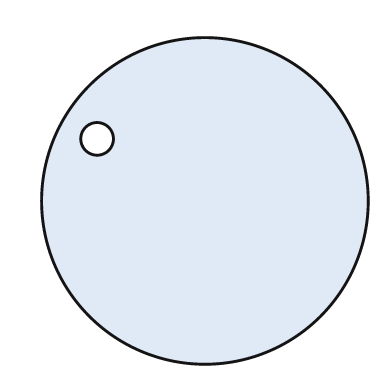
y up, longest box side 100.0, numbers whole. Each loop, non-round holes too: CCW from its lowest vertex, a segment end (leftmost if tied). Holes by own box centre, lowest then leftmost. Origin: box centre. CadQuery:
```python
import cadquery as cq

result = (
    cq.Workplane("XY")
    .moveTo(0.0, 0.0)
    .circle(50.0)
    .moveTo(-33.0, 19.0)
    .circle(5.0)
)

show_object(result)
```